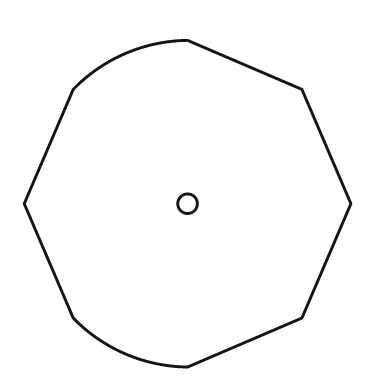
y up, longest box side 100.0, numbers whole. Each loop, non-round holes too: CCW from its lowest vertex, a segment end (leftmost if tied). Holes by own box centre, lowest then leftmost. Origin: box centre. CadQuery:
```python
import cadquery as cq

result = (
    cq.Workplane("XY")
    .moveTo(0.0, -50.0)
    .lineTo(35.0, -35.0)
    .lineTo(50.0, 0.0)
    .lineTo(35.0, 35.0)
    .lineTo(0.0, 50.0)
    .threePointArc((-19.0, 46.0), (-35.0, 35.0))
    .lineTo(-50.0, 0.0)
    .lineTo(-35.0, -35.0)
    .threePointArc((-19.0, -46.0), (0.0, -50.0))
    .close()
    .moveTo(0.0, 0.0)
    .circle(3.0)
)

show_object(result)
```